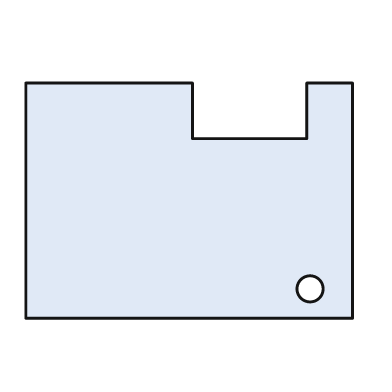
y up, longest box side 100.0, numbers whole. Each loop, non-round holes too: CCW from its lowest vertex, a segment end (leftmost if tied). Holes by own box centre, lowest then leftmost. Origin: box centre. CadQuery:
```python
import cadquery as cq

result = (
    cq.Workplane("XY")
    .moveTo(-50.0, -36.0)
    .lineTo(50.0, -36.0)
    .lineTo(50.0, 36.0)
    .lineTo(36.0, 36.0)
    .lineTo(36.0, 19.0)
    .lineTo(1.0, 19.0)
    .lineTo(1.0, 36.0)
    .lineTo(-50.0, 36.0)
    .close()
    .moveTo(37.0, -27.0)
    .circle(4.0)
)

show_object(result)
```